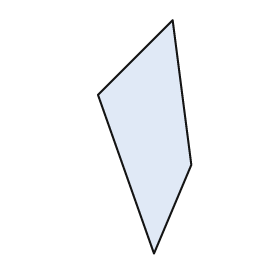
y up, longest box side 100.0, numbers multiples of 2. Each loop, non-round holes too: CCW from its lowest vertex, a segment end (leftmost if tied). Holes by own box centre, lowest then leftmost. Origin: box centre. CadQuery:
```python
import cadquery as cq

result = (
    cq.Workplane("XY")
    .moveTo(4.0, -50.0)
    .lineTo(20.0, -12.0)
    .lineTo(12.0, 50.0)
    .lineTo(-20.0, 18.0)
    .close()
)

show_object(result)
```